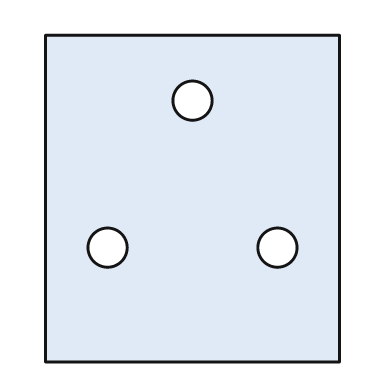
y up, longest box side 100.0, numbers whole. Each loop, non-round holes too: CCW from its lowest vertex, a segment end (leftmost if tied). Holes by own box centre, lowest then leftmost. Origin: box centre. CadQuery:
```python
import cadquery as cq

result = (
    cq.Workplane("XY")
    .moveTo(-45.0, -50.0)
    .lineTo(45.0, -50.0)
    .lineTo(45.0, 50.0)
    .lineTo(-45.0, 50.0)
    .close()
    .moveTo(-26.0, -15.0)
    .circle(6.0)
    .moveTo(26.0, -15.0)
    .circle(6.0)
    .moveTo(0.0, 30.0)
    .circle(6.0)
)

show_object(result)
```